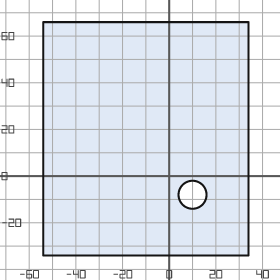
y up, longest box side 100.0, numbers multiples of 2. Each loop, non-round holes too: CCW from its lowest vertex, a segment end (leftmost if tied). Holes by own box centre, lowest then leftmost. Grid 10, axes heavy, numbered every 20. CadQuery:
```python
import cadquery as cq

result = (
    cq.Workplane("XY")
    .moveTo(-54.0, -34.0)
    .lineTo(34.0, -34.0)
    .lineTo(34.0, 66.0)
    .lineTo(-54.0, 66.0)
    .close()
    .moveTo(10.0, -8.0)
    .circle(6.0)
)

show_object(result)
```